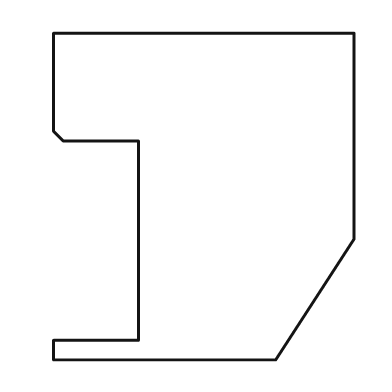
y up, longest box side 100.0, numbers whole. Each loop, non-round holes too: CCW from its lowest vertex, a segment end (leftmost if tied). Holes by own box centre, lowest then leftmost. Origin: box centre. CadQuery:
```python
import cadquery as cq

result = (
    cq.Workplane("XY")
    .moveTo(-46.0, -50.0)
    .lineTo(22.0, -50.0)
    .lineTo(46.0, -13.0)
    .lineTo(46.0, 50.0)
    .lineTo(-46.0, 50.0)
    .lineTo(-46.0, 20.0)
    .lineTo(-43.0, 17.0)
    .lineTo(-20.0, 17.0)
    .lineTo(-20.0, -44.0)
    .lineTo(-46.0, -44.0)
    .close()
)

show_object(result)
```